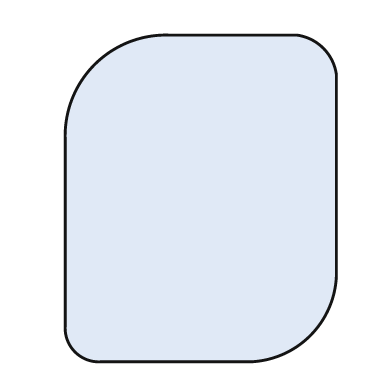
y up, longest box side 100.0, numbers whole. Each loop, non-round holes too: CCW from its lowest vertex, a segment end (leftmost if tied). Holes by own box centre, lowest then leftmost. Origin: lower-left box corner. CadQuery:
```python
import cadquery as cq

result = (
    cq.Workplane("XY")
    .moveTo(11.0, 0.0)
    .lineTo(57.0, 0.0)
    .threePointArc((75.0, 8.0), (83.0, 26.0))
    .lineTo(83.0, 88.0)
    .threePointArc((79.0, 96.0), (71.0, 100.0))
    .lineTo(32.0, 100.0)
    .threePointArc((9.0, 91.0), (0.0, 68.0))
    .lineTo(0.0, 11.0)
    .threePointArc((3.0, 3.0), (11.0, 0.0))
    .close()
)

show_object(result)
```